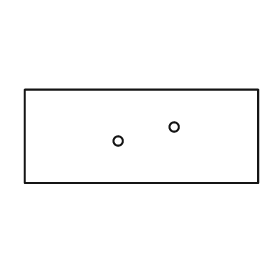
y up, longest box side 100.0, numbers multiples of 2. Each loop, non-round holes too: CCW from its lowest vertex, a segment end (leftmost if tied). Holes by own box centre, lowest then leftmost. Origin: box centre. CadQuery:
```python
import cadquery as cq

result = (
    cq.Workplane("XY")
    .moveTo(-50.0, -20.0)
    .lineTo(50.0, -20.0)
    .lineTo(50.0, 20.0)
    .lineTo(-50.0, 20.0)
    .close()
    .moveTo(-10.0, -2.0)
    .circle(2.0)
    .moveTo(14.0, 4.0)
    .circle(2.0)
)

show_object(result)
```